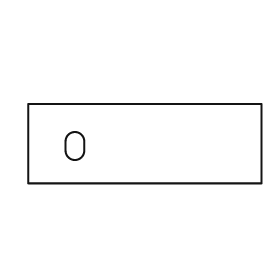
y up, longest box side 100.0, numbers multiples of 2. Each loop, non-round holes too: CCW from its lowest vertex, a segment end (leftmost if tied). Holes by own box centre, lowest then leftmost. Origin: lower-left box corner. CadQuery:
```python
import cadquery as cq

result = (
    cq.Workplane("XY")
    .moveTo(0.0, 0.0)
    .lineTo(100.0, 0.0)
    .lineTo(100.0, 34.0)
    .lineTo(0.0, 34.0)
    .close()
    .moveTo(16.0, 14.0)
    .threePointArc((20.0, 10.0), (24.0, 14.0))
    .lineTo(24.0, 18.0)
    .threePointArc((20.0, 22.0), (16.0, 18.0))
    .close()
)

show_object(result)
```